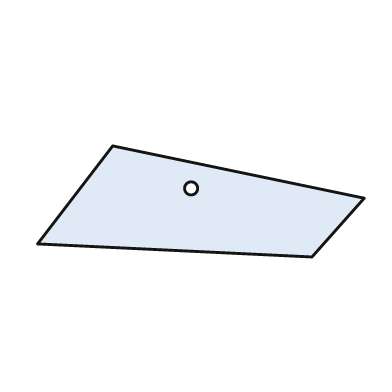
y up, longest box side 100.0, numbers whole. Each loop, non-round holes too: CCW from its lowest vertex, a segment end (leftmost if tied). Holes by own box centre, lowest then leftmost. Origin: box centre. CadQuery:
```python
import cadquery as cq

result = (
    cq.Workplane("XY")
    .moveTo(34.0, -17.0)
    .lineTo(50.0, 1.0)
    .lineTo(-27.0, 17.0)
    .lineTo(-50.0, -13.0)
    .close()
    .moveTo(-3.0, 4.0)
    .circle(2.0)
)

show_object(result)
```